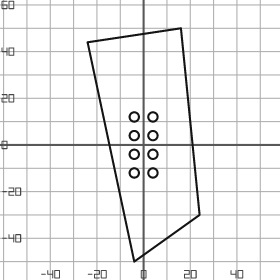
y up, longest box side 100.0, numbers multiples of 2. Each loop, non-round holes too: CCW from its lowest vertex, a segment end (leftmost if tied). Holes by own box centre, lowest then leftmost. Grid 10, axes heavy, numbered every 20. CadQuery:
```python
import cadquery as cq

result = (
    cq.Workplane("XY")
    .moveTo(-4.0, -50.0)
    .lineTo(24.0, -30.0)
    .lineTo(16.0, 50.0)
    .lineTo(-24.0, 44.0)
    .close()
    .moveTo(-4.0, -12.0)
    .circle(2.0)
    .moveTo(4.0, -12.0)
    .circle(2.0)
    .moveTo(-4.0, -4.0)
    .circle(2.0)
    .moveTo(4.0, -4.0)
    .circle(2.0)
    .moveTo(-4.0, 4.0)
    .circle(2.0)
    .moveTo(4.0, 4.0)
    .circle(2.0)
    .moveTo(-4.0, 12.0)
    .circle(2.0)
    .moveTo(4.0, 12.0)
    .circle(2.0)
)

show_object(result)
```